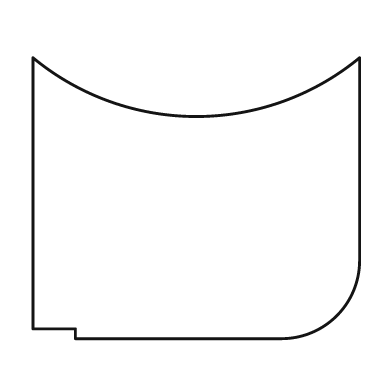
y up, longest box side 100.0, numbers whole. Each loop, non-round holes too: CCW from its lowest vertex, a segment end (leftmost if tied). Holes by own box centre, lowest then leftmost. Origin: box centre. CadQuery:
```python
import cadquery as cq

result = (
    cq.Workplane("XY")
    .moveTo(-37.0, -43.0)
    .lineTo(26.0, -43.0)
    .threePointArc((43.0, -36.0), (50.0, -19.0))
    .lineTo(50.0, 43.0)
    .threePointArc((0.0, 25.0), (-50.0, 43.0))
    .lineTo(-50.0, -40.0)
    .lineTo(-37.0, -40.0)
    .close()
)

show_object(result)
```